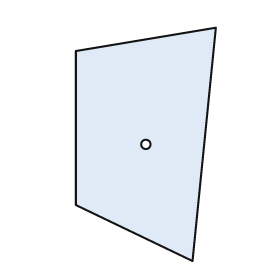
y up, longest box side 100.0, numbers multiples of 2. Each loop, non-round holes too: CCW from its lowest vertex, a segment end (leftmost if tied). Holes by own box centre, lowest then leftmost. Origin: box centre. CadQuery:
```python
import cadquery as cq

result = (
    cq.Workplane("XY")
    .moveTo(20.0, -50.0)
    .lineTo(30.0, 50.0)
    .lineTo(-30.0, 40.0)
    .lineTo(-30.0, -26.0)
    .close()
    .moveTo(0.0, 0.0)
    .circle(2.0)
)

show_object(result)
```